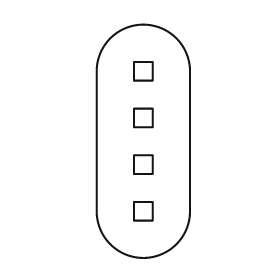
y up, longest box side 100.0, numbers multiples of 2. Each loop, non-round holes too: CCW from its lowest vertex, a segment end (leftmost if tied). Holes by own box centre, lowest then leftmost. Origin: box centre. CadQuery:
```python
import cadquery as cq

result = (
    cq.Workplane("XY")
    .moveTo(-20.0, -30.0)
    .threePointArc((0.0, -50.0), (20.0, -30.0))
    .lineTo(20.0, 30.0)
    .threePointArc((0.0, 50.0), (-20.0, 30.0))
    .close()
    .moveTo(-4.0, -34.0)
    .lineTo(4.0, -34.0)
    .lineTo(4.0, -26.0)
    .lineTo(-4.0, -26.0)
    .close()
    .moveTo(-4.0, -14.0)
    .lineTo(4.0, -14.0)
    .lineTo(4.0, -6.0)
    .lineTo(-4.0, -6.0)
    .close()
    .moveTo(-4.0, 6.0)
    .lineTo(4.0, 6.0)
    .lineTo(4.0, 14.0)
    .lineTo(-4.0, 14.0)
    .close()
    .moveTo(-4.0, 26.0)
    .lineTo(4.0, 26.0)
    .lineTo(4.0, 34.0)
    .lineTo(-4.0, 34.0)
    .close()
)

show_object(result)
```